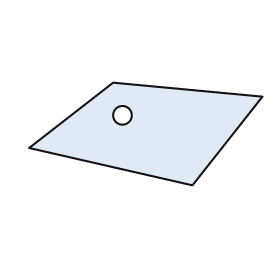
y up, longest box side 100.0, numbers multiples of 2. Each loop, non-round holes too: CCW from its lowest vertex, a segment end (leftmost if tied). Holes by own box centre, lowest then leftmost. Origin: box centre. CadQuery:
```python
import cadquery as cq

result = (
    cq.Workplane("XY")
    .moveTo(20.0, -22.0)
    .lineTo(50.0, 16.0)
    .lineTo(-14.0, 22.0)
    .lineTo(-50.0, -6.0)
    .close()
    .moveTo(-10.0, 8.0)
    .circle(4.0)
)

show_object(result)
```